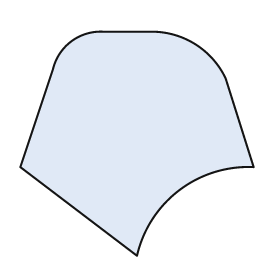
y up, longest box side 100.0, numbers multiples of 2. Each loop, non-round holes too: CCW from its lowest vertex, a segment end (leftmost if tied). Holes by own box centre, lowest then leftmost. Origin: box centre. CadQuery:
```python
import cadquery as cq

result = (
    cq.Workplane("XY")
    .moveTo(0.0, -48.0)
    .threePointArc((18.0, -20.0), (50.0, -10.0))
    .lineTo(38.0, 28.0)
    .threePointArc((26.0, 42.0), (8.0, 48.0))
    .lineTo(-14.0, 48.0)
    .threePointArc((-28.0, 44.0), (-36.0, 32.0))
    .lineTo(-50.0, -10.0)
    .close()
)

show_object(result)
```